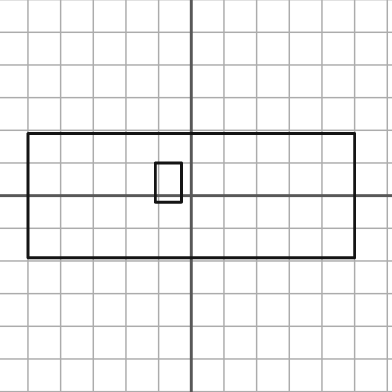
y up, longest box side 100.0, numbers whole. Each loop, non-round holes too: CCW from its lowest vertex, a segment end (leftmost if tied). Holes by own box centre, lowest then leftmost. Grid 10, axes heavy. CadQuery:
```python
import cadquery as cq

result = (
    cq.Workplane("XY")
    .moveTo(-50.0, -19.0)
    .lineTo(50.0, -19.0)
    .lineTo(50.0, 19.0)
    .lineTo(-50.0, 19.0)
    .close()
    .moveTo(-11.0, -2.0)
    .lineTo(-3.0, -2.0)
    .lineTo(-3.0, 10.0)
    .lineTo(-11.0, 10.0)
    .close()
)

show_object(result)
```